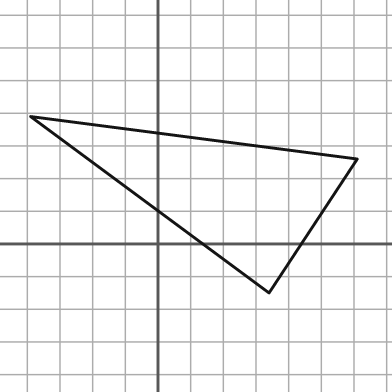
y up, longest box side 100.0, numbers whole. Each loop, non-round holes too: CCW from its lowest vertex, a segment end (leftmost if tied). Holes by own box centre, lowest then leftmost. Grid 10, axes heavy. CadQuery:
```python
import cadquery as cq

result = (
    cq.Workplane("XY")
    .moveTo(34.0, -15.0)
    .lineTo(61.0, 26.0)
    .lineTo(-39.0, 39.0)
    .close()
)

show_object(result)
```